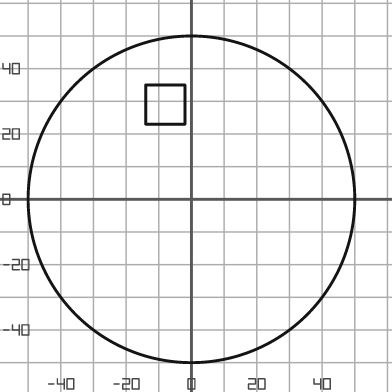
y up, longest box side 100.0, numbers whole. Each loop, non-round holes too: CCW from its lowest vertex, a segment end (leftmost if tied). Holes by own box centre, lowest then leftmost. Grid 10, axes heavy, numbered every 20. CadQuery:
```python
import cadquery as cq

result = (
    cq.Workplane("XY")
    .moveTo(0.0, 0.0)
    .circle(50.0)
    .moveTo(-14.0, 23.0)
    .lineTo(-2.0, 23.0)
    .lineTo(-2.0, 35.0)
    .lineTo(-14.0, 35.0)
    .close()
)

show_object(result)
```